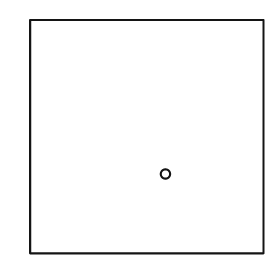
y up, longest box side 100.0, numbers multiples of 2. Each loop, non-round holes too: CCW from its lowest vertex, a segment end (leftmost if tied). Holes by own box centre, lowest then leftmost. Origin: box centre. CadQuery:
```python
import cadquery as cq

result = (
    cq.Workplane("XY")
    .moveTo(-50.0, -50.0)
    .lineTo(50.0, -50.0)
    .lineTo(50.0, 50.0)
    .lineTo(-50.0, 50.0)
    .close()
    .moveTo(8.0, -16.0)
    .circle(2.0)
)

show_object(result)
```